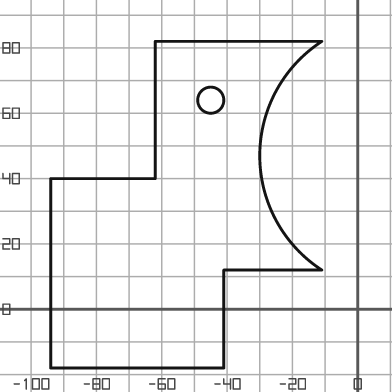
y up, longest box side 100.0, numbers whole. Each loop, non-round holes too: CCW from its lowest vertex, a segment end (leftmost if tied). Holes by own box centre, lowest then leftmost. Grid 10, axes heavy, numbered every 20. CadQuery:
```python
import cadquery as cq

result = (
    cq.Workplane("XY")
    .moveTo(-94.0, -18.0)
    .lineTo(-41.0, -18.0)
    .lineTo(-41.0, 12.0)
    .lineTo(-11.0, 12.0)
    .threePointArc((-30.0, 47.0), (-11.0, 82.0))
    .lineTo(-62.0, 82.0)
    .lineTo(-62.0, 40.0)
    .lineTo(-94.0, 40.0)
    .close()
    .moveTo(-45.0, 64.0)
    .circle(4.0)
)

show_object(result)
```